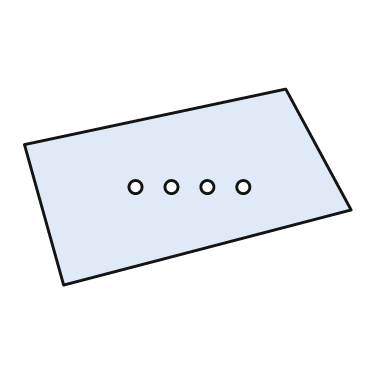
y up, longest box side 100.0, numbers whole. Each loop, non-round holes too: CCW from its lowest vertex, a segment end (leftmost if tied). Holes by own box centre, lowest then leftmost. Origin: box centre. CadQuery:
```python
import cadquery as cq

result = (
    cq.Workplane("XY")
    .moveTo(-38.0, -30.0)
    .lineTo(50.0, -7.0)
    .lineTo(30.0, 30.0)
    .lineTo(-50.0, 13.0)
    .close()
    .moveTo(-16.0, 0.0)
    .circle(2.0)
    .moveTo(-5.0, 0.0)
    .circle(2.0)
    .moveTo(6.0, 0.0)
    .circle(2.0)
    .moveTo(17.0, 0.0)
    .circle(2.0)
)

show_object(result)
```